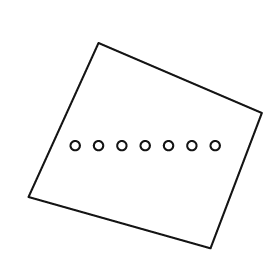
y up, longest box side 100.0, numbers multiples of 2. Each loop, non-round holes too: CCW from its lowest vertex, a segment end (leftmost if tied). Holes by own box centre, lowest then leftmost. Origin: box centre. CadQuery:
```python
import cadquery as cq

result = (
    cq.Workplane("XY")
    .moveTo(28.0, -44.0)
    .lineTo(50.0, 14.0)
    .lineTo(-20.0, 44.0)
    .lineTo(-50.0, -22.0)
    .close()
    .moveTo(-30.0, 0.0)
    .circle(2.0)
    .moveTo(-20.0, 0.0)
    .circle(2.0)
    .moveTo(-10.0, 0.0)
    .circle(2.0)
    .moveTo(0.0, 0.0)
    .circle(2.0)
    .moveTo(10.0, 0.0)
    .circle(2.0)
    .moveTo(20.0, 0.0)
    .circle(2.0)
    .moveTo(30.0, 0.0)
    .circle(2.0)
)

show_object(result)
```